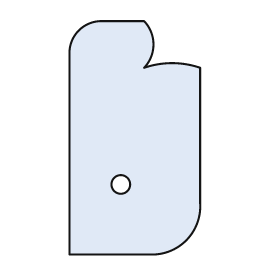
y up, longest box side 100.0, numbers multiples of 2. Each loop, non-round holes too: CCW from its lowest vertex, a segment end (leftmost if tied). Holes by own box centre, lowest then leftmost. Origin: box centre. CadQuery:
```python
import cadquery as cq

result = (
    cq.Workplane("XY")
    .moveTo(-28.0, -50.0)
    .lineTo(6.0, -50.0)
    .threePointArc((22.0, -44.0), (28.0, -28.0))
    .lineTo(28.0, 30.0)
    .threePointArc((16.0, 32.0), (4.0, 30.0))
    .threePointArc((8.0, 40.0), (4.0, 50.0))
    .lineTo(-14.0, 50.0)
    .threePointArc((-24.0, 46.0), (-28.0, 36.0))
    .close()
    .moveTo(-6.0, -20.0)
    .circle(4.0)
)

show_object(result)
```